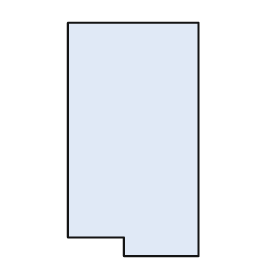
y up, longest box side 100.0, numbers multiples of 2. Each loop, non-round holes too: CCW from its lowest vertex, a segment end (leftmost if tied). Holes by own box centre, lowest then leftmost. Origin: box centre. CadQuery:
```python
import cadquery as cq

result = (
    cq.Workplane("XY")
    .moveTo(-4.0, -50.0)
    .lineTo(28.0, -50.0)
    .lineTo(28.0, 50.0)
    .lineTo(-28.0, 50.0)
    .lineTo(-28.0, -42.0)
    .lineTo(-4.0, -42.0)
    .close()
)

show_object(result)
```